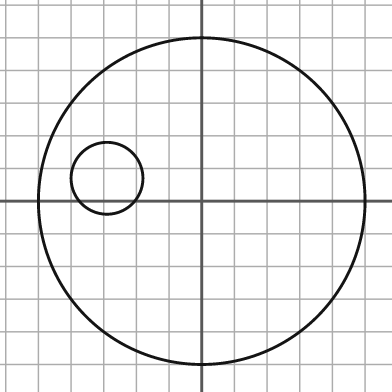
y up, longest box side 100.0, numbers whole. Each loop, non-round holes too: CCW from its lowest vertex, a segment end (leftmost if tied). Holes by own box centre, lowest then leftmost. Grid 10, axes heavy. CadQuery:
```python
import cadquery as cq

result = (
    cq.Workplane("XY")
    .moveTo(0.0, 0.0)
    .circle(50.0)
    .moveTo(-29.0, 7.0)
    .circle(11.0)
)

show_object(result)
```